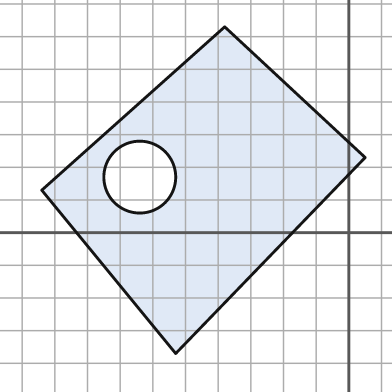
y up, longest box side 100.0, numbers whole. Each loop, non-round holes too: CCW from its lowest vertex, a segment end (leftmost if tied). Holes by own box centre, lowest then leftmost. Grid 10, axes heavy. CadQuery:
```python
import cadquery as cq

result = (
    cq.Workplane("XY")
    .moveTo(-53.0, -37.0)
    .lineTo(5.0, 23.0)
    .lineTo(-38.0, 63.0)
    .lineTo(-94.0, 13.0)
    .close()
    .moveTo(-64.0, 17.0)
    .circle(11.0)
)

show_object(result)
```